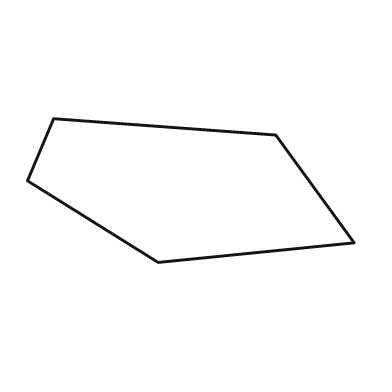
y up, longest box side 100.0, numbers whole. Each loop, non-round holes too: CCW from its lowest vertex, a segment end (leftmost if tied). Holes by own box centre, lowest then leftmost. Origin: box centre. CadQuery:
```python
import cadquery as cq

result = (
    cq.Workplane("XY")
    .moveTo(-10.0, -22.0)
    .lineTo(50.0, -16.0)
    .lineTo(26.0, 17.0)
    .lineTo(-42.0, 22.0)
    .lineTo(-50.0, 3.0)
    .close()
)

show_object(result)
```